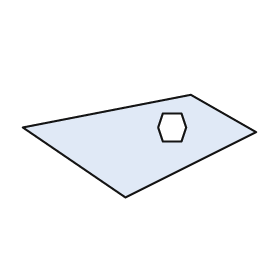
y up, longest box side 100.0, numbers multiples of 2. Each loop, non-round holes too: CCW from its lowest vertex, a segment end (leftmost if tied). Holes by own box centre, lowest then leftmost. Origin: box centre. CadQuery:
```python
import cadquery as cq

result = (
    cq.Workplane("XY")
    .moveTo(-6.0, -22.0)
    .lineTo(50.0, 6.0)
    .lineTo(22.0, 22.0)
    .lineTo(-50.0, 8.0)
    .close()
    .moveTo(10.0, 2.0)
    .lineTo(18.0, 2.0)
    .lineTo(20.0, 8.0)
    .lineTo(18.0, 14.0)
    .lineTo(10.0, 14.0)
    .lineTo(8.0, 8.0)
    .close()
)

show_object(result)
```